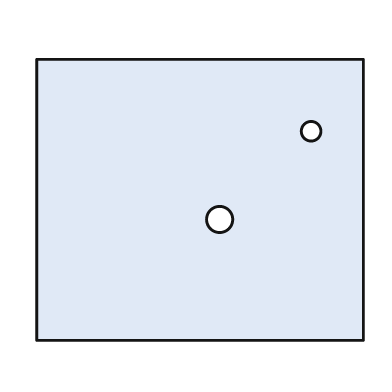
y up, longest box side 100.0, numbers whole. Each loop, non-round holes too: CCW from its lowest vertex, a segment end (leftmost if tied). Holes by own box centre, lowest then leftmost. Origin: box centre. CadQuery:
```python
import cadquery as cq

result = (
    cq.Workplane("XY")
    .moveTo(-50.0, -43.0)
    .lineTo(50.0, -43.0)
    .lineTo(50.0, 43.0)
    .lineTo(-50.0, 43.0)
    .close()
    .moveTo(6.0, -6.0)
    .circle(4.0)
    .moveTo(34.0, 21.0)
    .circle(3.0)
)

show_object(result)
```